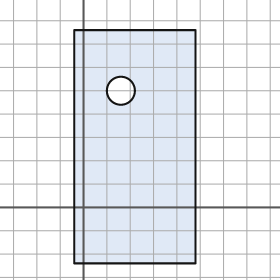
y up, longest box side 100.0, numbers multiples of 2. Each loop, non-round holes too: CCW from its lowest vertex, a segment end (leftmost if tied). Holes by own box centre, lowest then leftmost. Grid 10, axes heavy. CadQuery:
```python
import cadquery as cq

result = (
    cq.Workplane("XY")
    .moveTo(-4.0, -24.0)
    .lineTo(48.0, -24.0)
    .lineTo(48.0, 76.0)
    .lineTo(-4.0, 76.0)
    .close()
    .moveTo(16.0, 50.0)
    .circle(6.0)
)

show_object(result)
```